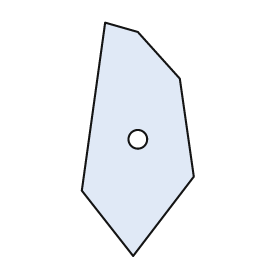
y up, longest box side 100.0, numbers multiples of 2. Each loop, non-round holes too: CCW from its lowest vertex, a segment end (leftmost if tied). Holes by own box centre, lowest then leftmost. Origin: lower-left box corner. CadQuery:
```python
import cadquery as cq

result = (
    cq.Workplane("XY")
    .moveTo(22.0, 0.0)
    .lineTo(48.0, 34.0)
    .lineTo(42.0, 76.0)
    .lineTo(24.0, 96.0)
    .lineTo(10.0, 100.0)
    .lineTo(0.0, 28.0)
    .close()
    .moveTo(24.0, 50.0)
    .circle(4.0)
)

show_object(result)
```